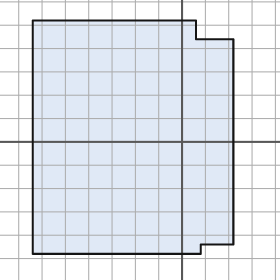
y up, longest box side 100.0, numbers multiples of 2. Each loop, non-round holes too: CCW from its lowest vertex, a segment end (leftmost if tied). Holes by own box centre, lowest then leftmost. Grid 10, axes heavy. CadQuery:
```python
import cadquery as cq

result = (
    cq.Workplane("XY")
    .moveTo(-64.0, -48.0)
    .lineTo(8.0, -48.0)
    .lineTo(8.0, -44.0)
    .lineTo(22.0, -44.0)
    .lineTo(22.0, 44.0)
    .lineTo(6.0, 44.0)
    .lineTo(6.0, 52.0)
    .lineTo(-64.0, 52.0)
    .close()
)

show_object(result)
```